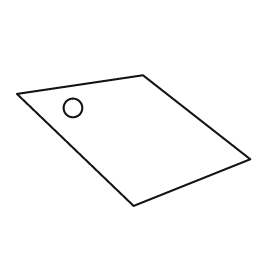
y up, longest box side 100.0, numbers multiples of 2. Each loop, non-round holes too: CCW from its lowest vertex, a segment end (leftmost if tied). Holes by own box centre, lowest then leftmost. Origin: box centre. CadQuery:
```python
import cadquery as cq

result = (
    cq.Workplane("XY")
    .moveTo(0.0, -28.0)
    .lineTo(50.0, -8.0)
    .lineTo(4.0, 28.0)
    .lineTo(-50.0, 20.0)
    .close()
    .moveTo(-26.0, 14.0)
    .circle(4.0)
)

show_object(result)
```